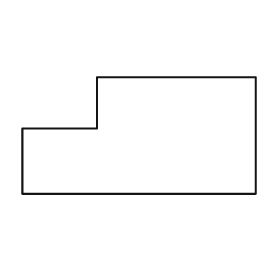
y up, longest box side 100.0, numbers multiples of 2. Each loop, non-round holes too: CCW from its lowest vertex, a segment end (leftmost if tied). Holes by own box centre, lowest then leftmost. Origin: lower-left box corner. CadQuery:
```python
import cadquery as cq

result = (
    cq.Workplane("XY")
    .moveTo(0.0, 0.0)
    .lineTo(100.0, 0.0)
    .lineTo(100.0, 50.0)
    .lineTo(32.0, 50.0)
    .lineTo(32.0, 28.0)
    .lineTo(0.0, 28.0)
    .close()
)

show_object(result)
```